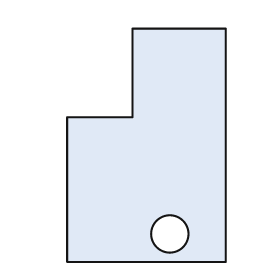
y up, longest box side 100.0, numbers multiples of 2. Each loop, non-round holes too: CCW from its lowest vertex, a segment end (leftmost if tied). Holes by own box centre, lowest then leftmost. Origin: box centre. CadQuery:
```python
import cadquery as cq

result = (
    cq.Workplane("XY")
    .moveTo(-34.0, -50.0)
    .lineTo(34.0, -50.0)
    .lineTo(34.0, 50.0)
    .lineTo(-6.0, 50.0)
    .lineTo(-6.0, 12.0)
    .lineTo(-34.0, 12.0)
    .close()
    .moveTo(10.0, -38.0)
    .circle(8.0)
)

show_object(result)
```